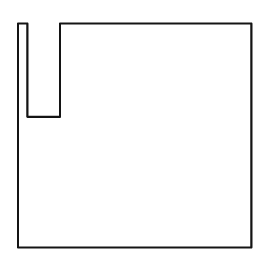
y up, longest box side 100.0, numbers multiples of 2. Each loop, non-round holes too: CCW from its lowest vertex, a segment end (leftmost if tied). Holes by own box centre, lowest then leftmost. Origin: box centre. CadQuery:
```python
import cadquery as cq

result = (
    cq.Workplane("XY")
    .moveTo(-50.0, -48.0)
    .lineTo(50.0, -48.0)
    .lineTo(50.0, 48.0)
    .lineTo(-32.0, 48.0)
    .lineTo(-32.0, 8.0)
    .lineTo(-46.0, 8.0)
    .lineTo(-46.0, 48.0)
    .lineTo(-50.0, 48.0)
    .close()
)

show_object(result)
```